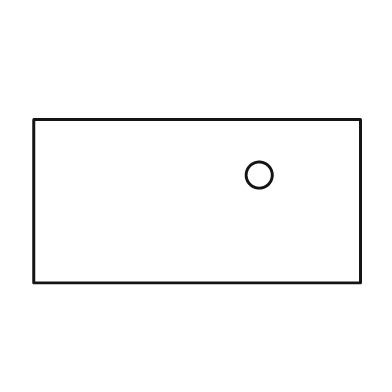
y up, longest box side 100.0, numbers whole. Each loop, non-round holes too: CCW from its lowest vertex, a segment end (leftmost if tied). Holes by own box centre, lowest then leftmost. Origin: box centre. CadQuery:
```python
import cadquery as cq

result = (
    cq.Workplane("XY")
    .moveTo(-50.0, -25.0)
    .lineTo(50.0, -25.0)
    .lineTo(50.0, 25.0)
    .lineTo(-50.0, 25.0)
    .close()
    .moveTo(19.0, 8.0)
    .circle(4.0)
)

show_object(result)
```